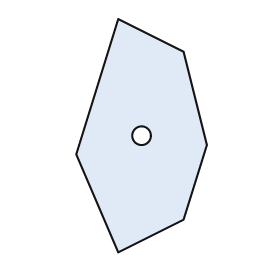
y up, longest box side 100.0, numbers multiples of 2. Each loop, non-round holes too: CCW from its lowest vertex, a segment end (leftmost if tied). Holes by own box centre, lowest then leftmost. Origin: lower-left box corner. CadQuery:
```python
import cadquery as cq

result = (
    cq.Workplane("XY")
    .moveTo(18.0, 0.0)
    .lineTo(46.0, 14.0)
    .lineTo(56.0, 46.0)
    .lineTo(46.0, 86.0)
    .lineTo(18.0, 100.0)
    .lineTo(0.0, 42.0)
    .close()
    .moveTo(28.0, 50.0)
    .circle(4.0)
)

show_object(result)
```